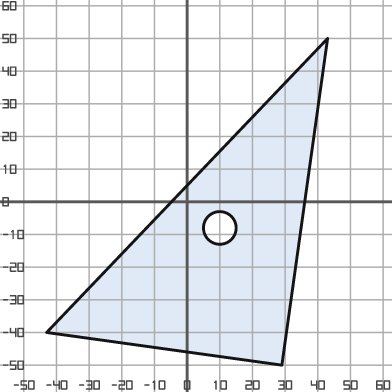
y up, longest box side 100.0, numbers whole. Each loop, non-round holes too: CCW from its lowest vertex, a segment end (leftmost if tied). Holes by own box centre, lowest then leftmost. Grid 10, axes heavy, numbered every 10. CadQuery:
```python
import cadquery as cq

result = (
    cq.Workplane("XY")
    .moveTo(29.0, -50.0)
    .lineTo(43.0, 50.0)
    .lineTo(-43.0, -40.0)
    .close()
    .moveTo(10.0, -8.0)
    .circle(5.0)
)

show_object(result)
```